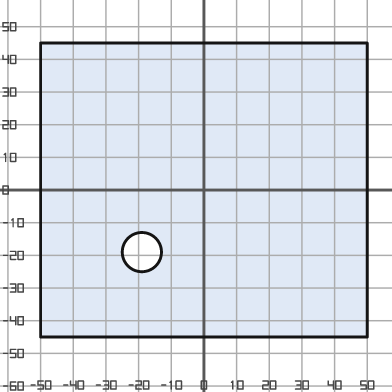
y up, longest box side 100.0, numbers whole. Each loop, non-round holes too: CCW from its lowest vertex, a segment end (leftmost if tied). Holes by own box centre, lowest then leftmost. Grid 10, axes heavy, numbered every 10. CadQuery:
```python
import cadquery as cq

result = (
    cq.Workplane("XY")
    .moveTo(-50.0, -45.0)
    .lineTo(50.0, -45.0)
    .lineTo(50.0, 45.0)
    .lineTo(-50.0, 45.0)
    .close()
    .moveTo(-19.0, -19.0)
    .circle(6.0)
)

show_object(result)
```